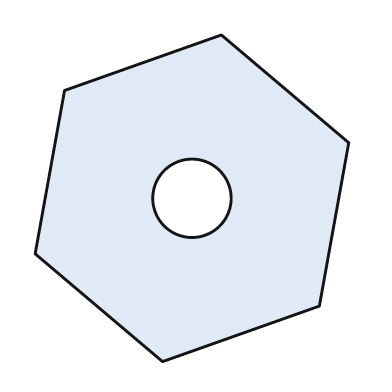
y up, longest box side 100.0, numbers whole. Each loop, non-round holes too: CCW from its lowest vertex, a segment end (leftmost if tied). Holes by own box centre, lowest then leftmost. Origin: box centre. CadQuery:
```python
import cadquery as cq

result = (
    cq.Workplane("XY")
    .moveTo(-9.0, -50.0)
    .lineTo(39.0, -33.0)
    .lineTo(48.0, 17.0)
    .lineTo(9.0, 50.0)
    .lineTo(-39.0, 33.0)
    .lineTo(-48.0, -17.0)
    .close()
    .moveTo(0.0, 0.0)
    .circle(12.0)
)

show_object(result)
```